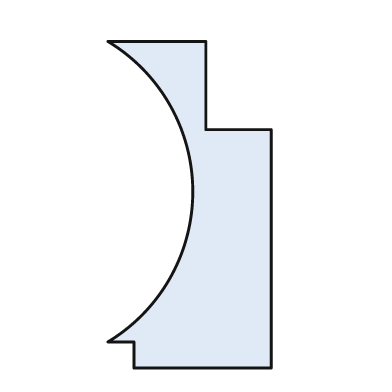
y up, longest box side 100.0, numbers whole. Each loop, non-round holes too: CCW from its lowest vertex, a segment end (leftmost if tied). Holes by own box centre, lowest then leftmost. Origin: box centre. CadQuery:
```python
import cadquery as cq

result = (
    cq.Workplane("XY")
    .moveTo(-17.0, -50.0)
    .lineTo(25.0, -50.0)
    .lineTo(25.0, 23.0)
    .lineTo(5.0, 23.0)
    .lineTo(5.0, 50.0)
    .lineTo(-25.0, 50.0)
    .threePointArc((1.0, 4.0), (-25.0, -42.0))
    .lineTo(-17.0, -42.0)
    .close()
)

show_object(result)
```